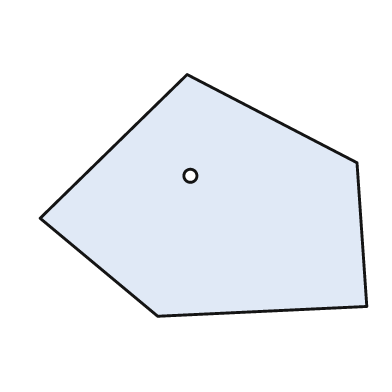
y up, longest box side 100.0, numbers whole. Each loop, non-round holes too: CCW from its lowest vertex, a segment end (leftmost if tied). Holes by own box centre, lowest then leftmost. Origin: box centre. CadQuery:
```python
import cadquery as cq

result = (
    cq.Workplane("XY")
    .moveTo(-14.0, -37.0)
    .lineTo(50.0, -34.0)
    .lineTo(47.0, 10.0)
    .lineTo(-5.0, 37.0)
    .lineTo(-50.0, -7.0)
    .close()
    .moveTo(-4.0, 6.0)
    .circle(2.0)
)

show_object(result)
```